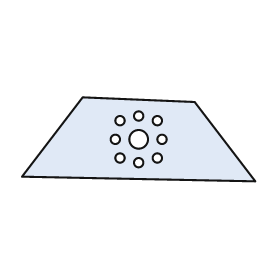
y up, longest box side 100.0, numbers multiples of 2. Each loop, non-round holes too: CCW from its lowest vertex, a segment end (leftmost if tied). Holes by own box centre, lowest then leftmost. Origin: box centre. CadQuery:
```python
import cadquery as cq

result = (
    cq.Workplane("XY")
    .moveTo(50.0, -18.0)
    .lineTo(24.0, 16.0)
    .lineTo(-24.0, 18.0)
    .lineTo(-50.0, -16.0)
    .close()
    .moveTo(0.0, -10.0)
    .circle(2.0)
    .moveTo(-8.0, -8.0)
    .circle(2.0)
    .moveTo(8.0, -8.0)
    .circle(2.0)
    .moveTo(-10.0, 0.0)
    .circle(2.0)
    .moveTo(0.0, 0.0)
    .circle(4.0)
    .moveTo(10.0, 0.0)
    .circle(2.0)
    .moveTo(-8.0, 8.0)
    .circle(2.0)
    .moveTo(8.0, 8.0)
    .circle(2.0)
    .moveTo(0.0, 10.0)
    .circle(2.0)
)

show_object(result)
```